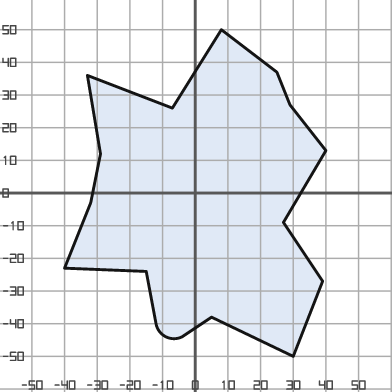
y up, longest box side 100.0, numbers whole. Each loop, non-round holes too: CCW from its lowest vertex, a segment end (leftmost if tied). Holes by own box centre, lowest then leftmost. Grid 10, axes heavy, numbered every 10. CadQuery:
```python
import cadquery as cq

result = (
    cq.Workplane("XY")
    .moveTo(30.0, -50.0)
    .lineTo(39.0, -27.0)
    .lineTo(27.0, -9.0)
    .lineTo(40.0, 13.0)
    .lineTo(29.0, 27.0)
    .lineTo(25.0, 37.0)
    .lineTo(8.0, 50.0)
    .lineTo(-7.0, 26.0)
    .lineTo(-33.0, 36.0)
    .lineTo(-29.0, 12.0)
    .lineTo(-32.0, -3.0)
    .lineTo(-40.0, -23.0)
    .lineTo(-15.0, -24.0)
    .lineTo(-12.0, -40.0)
    .threePointArc((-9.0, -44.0), (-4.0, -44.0))
    .lineTo(5.0, -38.0)
    .close()
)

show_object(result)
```